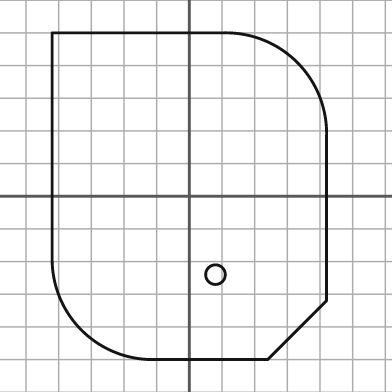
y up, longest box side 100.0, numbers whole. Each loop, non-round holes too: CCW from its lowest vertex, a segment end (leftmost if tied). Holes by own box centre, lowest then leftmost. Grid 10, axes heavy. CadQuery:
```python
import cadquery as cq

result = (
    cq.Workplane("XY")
    .moveTo(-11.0, -50.0)
    .lineTo(24.0, -50.0)
    .lineTo(42.0, -32.0)
    .lineTo(42.0, 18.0)
    .threePointArc((33.0, 41.0), (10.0, 50.0))
    .lineTo(-42.0, 50.0)
    .lineTo(-42.0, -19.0)
    .threePointArc((-33.0, -41.0), (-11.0, -50.0))
    .close()
    .moveTo(8.0, -24.0)
    .circle(3.0)
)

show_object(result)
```